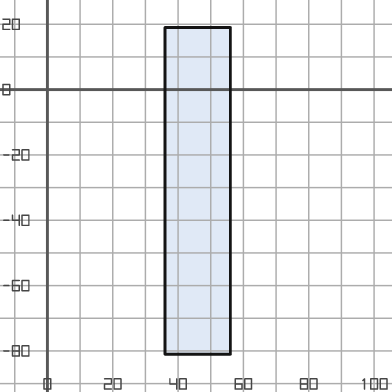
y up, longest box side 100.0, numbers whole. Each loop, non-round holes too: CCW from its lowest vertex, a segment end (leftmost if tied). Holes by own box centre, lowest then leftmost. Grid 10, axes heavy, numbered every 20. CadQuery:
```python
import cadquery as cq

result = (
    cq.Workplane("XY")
    .moveTo(36.0, -81.0)
    .lineTo(56.0, -81.0)
    .lineTo(56.0, 19.0)
    .lineTo(36.0, 19.0)
    .close()
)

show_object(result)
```